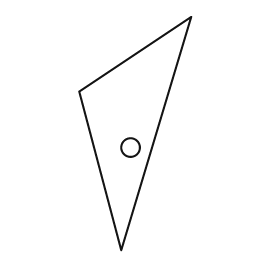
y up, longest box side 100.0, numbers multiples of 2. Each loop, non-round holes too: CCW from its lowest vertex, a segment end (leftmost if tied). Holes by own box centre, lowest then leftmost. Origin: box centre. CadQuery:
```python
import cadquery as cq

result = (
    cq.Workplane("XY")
    .moveTo(-6.0, -50.0)
    .lineTo(24.0, 50.0)
    .lineTo(-24.0, 18.0)
    .close()
    .moveTo(-2.0, -6.0)
    .circle(4.0)
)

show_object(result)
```